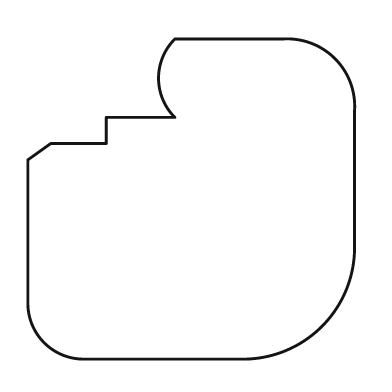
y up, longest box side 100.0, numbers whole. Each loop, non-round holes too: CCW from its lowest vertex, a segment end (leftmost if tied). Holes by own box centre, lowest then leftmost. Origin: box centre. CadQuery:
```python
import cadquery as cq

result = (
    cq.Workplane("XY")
    .moveTo(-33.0, -49.0)
    .lineTo(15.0, -49.0)
    .threePointArc((40.0, -39.0), (50.0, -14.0))
    .lineTo(50.0, 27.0)
    .threePointArc((44.0, 43.0), (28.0, 49.0))
    .lineTo(-5.0, 49.0)
    .threePointArc((-10.0, 37.0), (-5.0, 25.0))
    .lineTo(-26.0, 25.0)
    .lineTo(-26.0, 17.0)
    .lineTo(-43.0, 17.0)
    .lineTo(-50.0, 12.0)
    .lineTo(-50.0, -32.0)
    .threePointArc((-45.0, -44.0), (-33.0, -49.0))
    .close()
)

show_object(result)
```